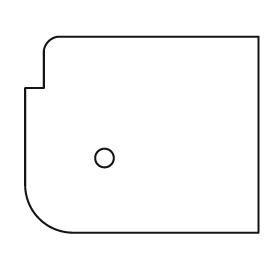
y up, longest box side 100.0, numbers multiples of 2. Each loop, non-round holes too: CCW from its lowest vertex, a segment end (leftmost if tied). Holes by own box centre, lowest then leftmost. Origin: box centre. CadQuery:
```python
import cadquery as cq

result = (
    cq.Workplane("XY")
    .moveTo(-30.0, -42.0)
    .lineTo(50.0, -42.0)
    .lineTo(50.0, 42.0)
    .lineTo(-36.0, 42.0)
    .threePointArc((-40.0, 40.0), (-42.0, 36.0))
    .lineTo(-42.0, 20.0)
    .lineTo(-50.0, 20.0)
    .lineTo(-50.0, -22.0)
    .threePointArc((-44.0, -36.0), (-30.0, -42.0))
    .close()
    .moveTo(-16.0, -10.0)
    .circle(4.0)
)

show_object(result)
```